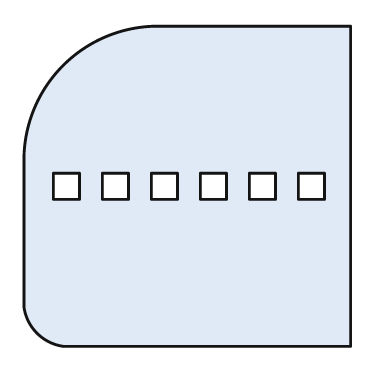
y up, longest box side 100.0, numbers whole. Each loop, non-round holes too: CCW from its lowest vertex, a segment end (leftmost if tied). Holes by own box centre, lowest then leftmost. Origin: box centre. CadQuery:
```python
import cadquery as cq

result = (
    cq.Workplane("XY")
    .moveTo(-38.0, -49.0)
    .lineTo(50.0, -49.0)
    .lineTo(50.0, 49.0)
    .lineTo(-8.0, 49.0)
    .threePointArc((-38.0, 37.0), (-50.0, 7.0))
    .lineTo(-50.0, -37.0)
    .threePointArc((-46.0, -45.0), (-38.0, -49.0))
    .close()
    .moveTo(-41.0, -4.0)
    .lineTo(-33.0, -4.0)
    .lineTo(-33.0, 4.0)
    .lineTo(-41.0, 4.0)
    .close()
    .moveTo(-26.0, -4.0)
    .lineTo(-18.0, -4.0)
    .lineTo(-18.0, 4.0)
    .lineTo(-26.0, 4.0)
    .close()
    .moveTo(-11.0, -4.0)
    .lineTo(-3.0, -4.0)
    .lineTo(-3.0, 4.0)
    .lineTo(-11.0, 4.0)
    .close()
    .moveTo(4.0, -4.0)
    .lineTo(12.0, -4.0)
    .lineTo(12.0, 4.0)
    .lineTo(4.0, 4.0)
    .close()
    .moveTo(19.0, -4.0)
    .lineTo(27.0, -4.0)
    .lineTo(27.0, 4.0)
    .lineTo(19.0, 4.0)
    .close()
    .moveTo(34.0, -4.0)
    .lineTo(42.0, -4.0)
    .lineTo(42.0, 4.0)
    .lineTo(34.0, 4.0)
    .close()
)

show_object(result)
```